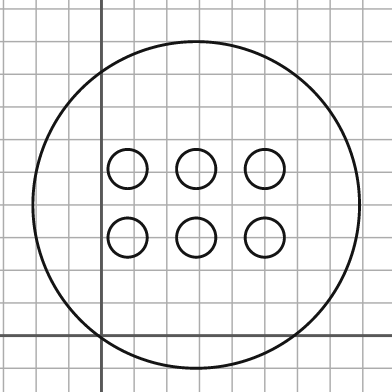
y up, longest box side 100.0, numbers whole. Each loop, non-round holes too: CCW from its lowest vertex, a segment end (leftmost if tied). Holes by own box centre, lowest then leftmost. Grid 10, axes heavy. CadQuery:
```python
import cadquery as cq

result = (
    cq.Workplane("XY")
    .moveTo(29.0, 40.0)
    .circle(50.0)
    .moveTo(8.0, 30.0)
    .circle(6.0)
    .moveTo(29.0, 30.0)
    .circle(6.0)
    .moveTo(50.0, 30.0)
    .circle(6.0)
    .moveTo(8.0, 51.0)
    .circle(6.0)
    .moveTo(29.0, 51.0)
    .circle(6.0)
    .moveTo(50.0, 51.0)
    .circle(6.0)
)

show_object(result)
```